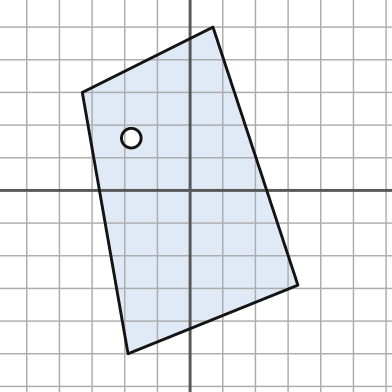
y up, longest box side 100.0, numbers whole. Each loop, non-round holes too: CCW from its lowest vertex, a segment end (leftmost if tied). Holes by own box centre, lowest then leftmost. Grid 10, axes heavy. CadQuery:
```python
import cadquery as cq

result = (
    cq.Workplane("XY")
    .moveTo(-19.0, -50.0)
    .lineTo(33.0, -29.0)
    .lineTo(7.0, 50.0)
    .lineTo(-33.0, 30.0)
    .close()
    .moveTo(-18.0, 16.0)
    .circle(3.0)
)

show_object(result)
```